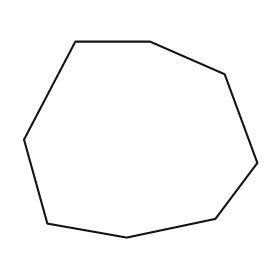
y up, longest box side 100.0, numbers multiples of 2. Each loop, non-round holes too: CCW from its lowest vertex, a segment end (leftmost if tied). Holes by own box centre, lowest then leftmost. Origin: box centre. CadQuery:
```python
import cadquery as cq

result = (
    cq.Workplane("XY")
    .moveTo(-6.0, -42.0)
    .lineTo(32.0, -34.0)
    .lineTo(50.0, -10.0)
    .lineTo(36.0, 28.0)
    .lineTo(4.0, 42.0)
    .lineTo(-28.0, 42.0)
    .lineTo(-50.0, 0.0)
    .lineTo(-40.0, -36.0)
    .close()
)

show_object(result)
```